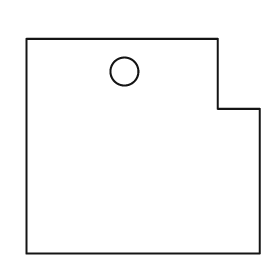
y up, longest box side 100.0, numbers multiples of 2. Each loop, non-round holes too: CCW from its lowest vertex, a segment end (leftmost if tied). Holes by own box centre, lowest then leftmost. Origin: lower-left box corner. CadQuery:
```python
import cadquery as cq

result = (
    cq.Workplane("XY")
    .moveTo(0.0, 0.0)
    .lineTo(100.0, 0.0)
    .lineTo(100.0, 62.0)
    .lineTo(82.0, 62.0)
    .lineTo(82.0, 92.0)
    .lineTo(0.0, 92.0)
    .close()
    .moveTo(42.0, 78.0)
    .circle(6.0)
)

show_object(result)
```